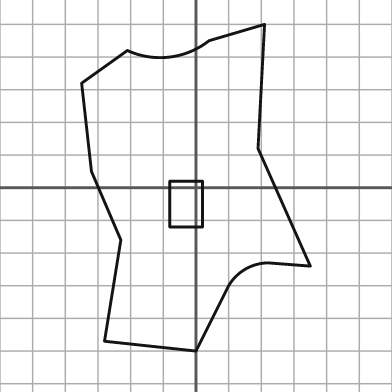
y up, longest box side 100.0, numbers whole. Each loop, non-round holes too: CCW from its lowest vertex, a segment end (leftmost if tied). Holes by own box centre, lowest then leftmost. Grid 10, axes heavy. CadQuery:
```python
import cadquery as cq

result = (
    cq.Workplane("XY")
    .moveTo(0.0, -50.0)
    .lineTo(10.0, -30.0)
    .threePointArc((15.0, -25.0), (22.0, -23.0))
    .lineTo(35.0, -24.0)
    .lineTo(19.0, 12.0)
    .lineTo(21.0, 50.0)
    .lineTo(4.0, 45.0)
    .threePointArc((-8.0, 40.0), (-21.0, 42.0))
    .lineTo(-35.0, 32.0)
    .lineTo(-32.0, 5.0)
    .lineTo(-23.0, -16.0)
    .lineTo(-28.0, -47.0)
    .close()
    .moveTo(-8.0, -12.0)
    .lineTo(2.0, -12.0)
    .lineTo(2.0, 2.0)
    .lineTo(-8.0, 2.0)
    .close()
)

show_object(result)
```